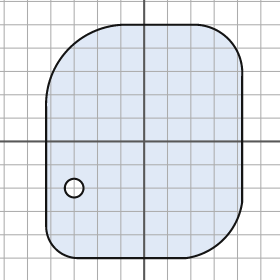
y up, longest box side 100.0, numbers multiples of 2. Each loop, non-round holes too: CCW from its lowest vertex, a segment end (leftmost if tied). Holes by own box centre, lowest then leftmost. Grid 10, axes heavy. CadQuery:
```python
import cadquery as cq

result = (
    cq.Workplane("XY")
    .moveTo(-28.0, -50.0)
    .lineTo(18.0, -50.0)
    .threePointArc((34.0, -42.0), (42.0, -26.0))
    .lineTo(42.0, 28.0)
    .threePointArc((36.0, 44.0), (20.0, 50.0))
    .lineTo(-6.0, 50.0)
    .threePointArc((-32.0, 40.0), (-42.0, 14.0))
    .lineTo(-42.0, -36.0)
    .threePointArc((-38.0, -46.0), (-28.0, -50.0))
    .close()
    .moveTo(-30.0, -20.0)
    .circle(4.0)
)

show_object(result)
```